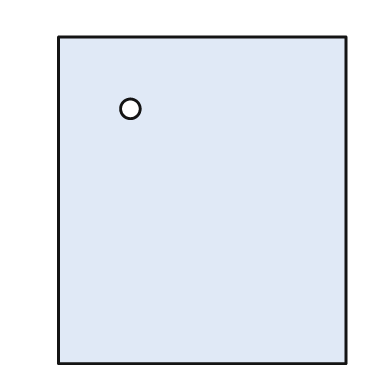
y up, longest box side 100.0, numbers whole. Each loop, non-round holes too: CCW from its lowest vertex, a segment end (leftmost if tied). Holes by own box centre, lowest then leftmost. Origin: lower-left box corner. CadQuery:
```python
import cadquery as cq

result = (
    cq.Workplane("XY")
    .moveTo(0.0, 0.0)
    .lineTo(88.0, 0.0)
    .lineTo(88.0, 100.0)
    .lineTo(0.0, 100.0)
    .close()
    .moveTo(22.0, 78.0)
    .circle(3.0)
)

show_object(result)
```